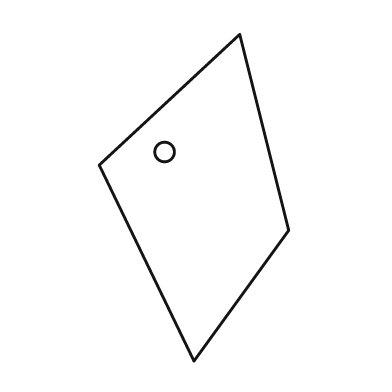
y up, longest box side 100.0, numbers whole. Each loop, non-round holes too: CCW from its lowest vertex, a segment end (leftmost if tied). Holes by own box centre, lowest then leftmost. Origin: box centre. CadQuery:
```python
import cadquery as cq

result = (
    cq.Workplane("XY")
    .moveTo(0.0, -50.0)
    .lineTo(29.0, -10.0)
    .lineTo(14.0, 50.0)
    .lineTo(-29.0, 10.0)
    .close()
    .moveTo(-9.0, 14.0)
    .circle(3.0)
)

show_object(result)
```